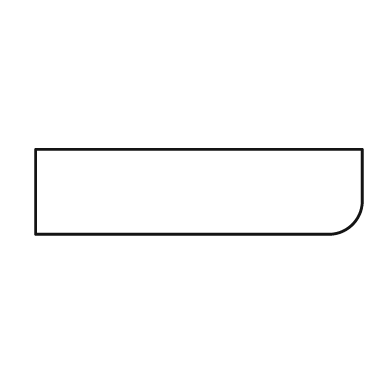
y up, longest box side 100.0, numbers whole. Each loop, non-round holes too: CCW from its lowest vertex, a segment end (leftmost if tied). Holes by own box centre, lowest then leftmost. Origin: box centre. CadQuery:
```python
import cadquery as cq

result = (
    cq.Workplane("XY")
    .moveTo(-50.0, -13.0)
    .lineTo(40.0, -13.0)
    .threePointArc((47.0, -10.0), (50.0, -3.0))
    .lineTo(50.0, 13.0)
    .lineTo(-50.0, 13.0)
    .close()
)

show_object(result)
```